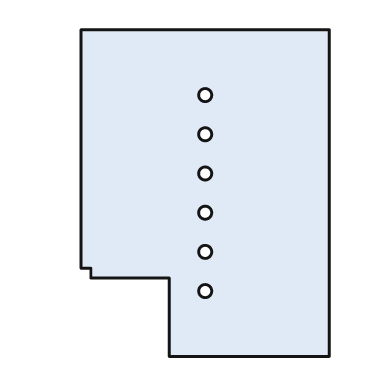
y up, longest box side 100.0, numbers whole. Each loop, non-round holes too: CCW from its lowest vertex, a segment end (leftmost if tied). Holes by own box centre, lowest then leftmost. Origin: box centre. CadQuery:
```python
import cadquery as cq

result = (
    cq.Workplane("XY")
    .moveTo(-11.0, -50.0)
    .lineTo(38.0, -50.0)
    .lineTo(38.0, 50.0)
    .lineTo(-38.0, 50.0)
    .lineTo(-38.0, -23.0)
    .lineTo(-35.0, -23.0)
    .lineTo(-35.0, -26.0)
    .lineTo(-11.0, -26.0)
    .close()
    .moveTo(0.0, -30.0)
    .circle(2.0)
    .moveTo(0.0, -18.0)
    .circle(2.0)
    .moveTo(0.0, -6.0)
    .circle(2.0)
    .moveTo(0.0, 6.0)
    .circle(2.0)
    .moveTo(0.0, 18.0)
    .circle(2.0)
    .moveTo(0.0, 30.0)
    .circle(2.0)
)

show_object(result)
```